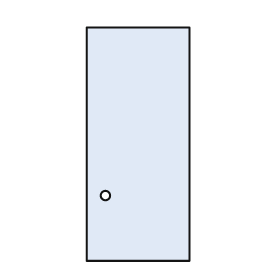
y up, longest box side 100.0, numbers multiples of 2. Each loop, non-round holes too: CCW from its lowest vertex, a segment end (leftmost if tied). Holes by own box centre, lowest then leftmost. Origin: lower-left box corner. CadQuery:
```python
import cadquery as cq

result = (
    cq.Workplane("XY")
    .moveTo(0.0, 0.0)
    .lineTo(44.0, 0.0)
    .lineTo(44.0, 100.0)
    .lineTo(0.0, 100.0)
    .close()
    .moveTo(8.0, 28.0)
    .circle(2.0)
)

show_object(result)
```